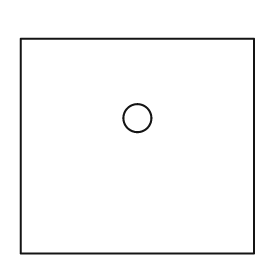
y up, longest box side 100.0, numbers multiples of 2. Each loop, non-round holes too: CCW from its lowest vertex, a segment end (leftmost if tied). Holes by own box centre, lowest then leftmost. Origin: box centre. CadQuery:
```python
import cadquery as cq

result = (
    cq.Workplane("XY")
    .moveTo(-50.0, -46.0)
    .lineTo(50.0, -46.0)
    .lineTo(50.0, 46.0)
    .lineTo(-50.0, 46.0)
    .close()
    .moveTo(0.0, 12.0)
    .circle(6.0)
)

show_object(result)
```